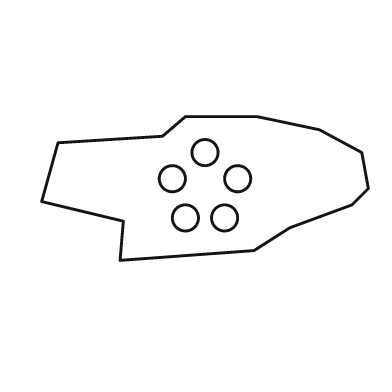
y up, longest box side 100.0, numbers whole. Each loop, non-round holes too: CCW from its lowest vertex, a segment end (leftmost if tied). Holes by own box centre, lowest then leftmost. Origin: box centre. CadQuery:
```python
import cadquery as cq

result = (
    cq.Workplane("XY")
    .moveTo(-26.0, -22.0)
    .lineTo(15.0, -19.0)
    .lineTo(26.0, -12.0)
    .lineTo(45.0, -5.0)
    .lineTo(50.0, 0.0)
    .lineTo(48.0, 11.0)
    .lineTo(35.0, 18.0)
    .lineTo(16.0, 22.0)
    .lineTo(-6.0, 22.0)
    .lineTo(-13.0, 16.0)
    .lineTo(-45.0, 14.0)
    .lineTo(-50.0, -4.0)
    .lineTo(-25.0, -10.0)
    .close()
    .moveTo(-6.0, -9.0)
    .circle(4.0)
    .moveTo(6.0, -9.0)
    .circle(4.0)
    .moveTo(-10.0, 3.0)
    .circle(4.0)
    .moveTo(10.0, 3.0)
    .circle(4.0)
    .moveTo(0.0, 11.0)
    .circle(4.0)
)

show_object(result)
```